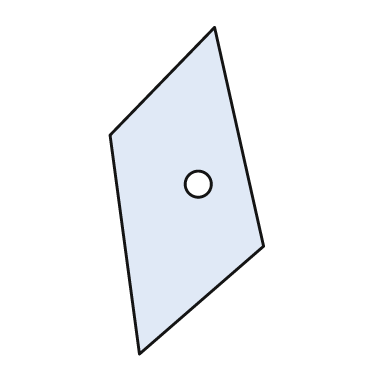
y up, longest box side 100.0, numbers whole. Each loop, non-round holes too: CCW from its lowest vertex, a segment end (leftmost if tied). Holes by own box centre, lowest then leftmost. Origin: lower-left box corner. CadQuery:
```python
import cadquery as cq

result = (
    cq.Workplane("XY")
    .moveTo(9.0, 0.0)
    .lineTo(47.0, 33.0)
    .lineTo(32.0, 100.0)
    .lineTo(0.0, 67.0)
    .close()
    .moveTo(27.0, 52.0)
    .circle(4.0)
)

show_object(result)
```